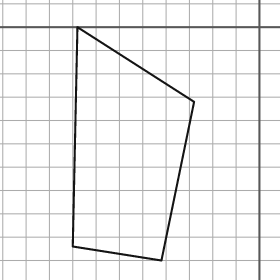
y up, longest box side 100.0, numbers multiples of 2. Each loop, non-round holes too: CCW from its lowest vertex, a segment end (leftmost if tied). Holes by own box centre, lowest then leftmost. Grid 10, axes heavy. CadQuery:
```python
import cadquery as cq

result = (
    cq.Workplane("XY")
    .moveTo(-42.0, -100.0)
    .lineTo(-28.0, -32.0)
    .lineTo(-78.0, 0.0)
    .lineTo(-80.0, -94.0)
    .close()
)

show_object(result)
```